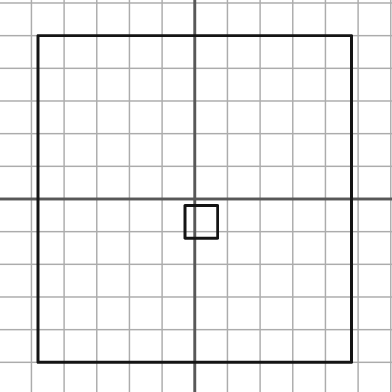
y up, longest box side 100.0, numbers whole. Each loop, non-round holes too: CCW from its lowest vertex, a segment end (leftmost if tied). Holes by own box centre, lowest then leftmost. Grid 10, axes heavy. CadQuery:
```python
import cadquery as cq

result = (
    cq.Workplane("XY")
    .moveTo(-48.0, -50.0)
    .lineTo(48.0, -50.0)
    .lineTo(48.0, 50.0)
    .lineTo(-48.0, 50.0)
    .close()
    .moveTo(-3.0, -12.0)
    .lineTo(7.0, -12.0)
    .lineTo(7.0, -2.0)
    .lineTo(-3.0, -2.0)
    .close()
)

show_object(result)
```